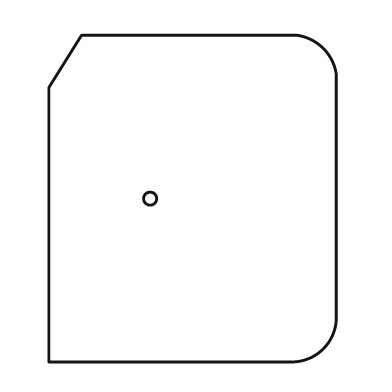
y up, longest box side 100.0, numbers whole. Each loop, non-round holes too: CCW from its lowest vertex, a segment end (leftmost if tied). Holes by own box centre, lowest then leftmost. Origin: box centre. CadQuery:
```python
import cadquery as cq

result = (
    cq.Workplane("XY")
    .moveTo(-44.0, -50.0)
    .lineTo(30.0, -50.0)
    .threePointArc((40.0, -46.0), (44.0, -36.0))
    .lineTo(44.0, 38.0)
    .threePointArc((40.0, 46.0), (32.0, 50.0))
    .lineTo(-34.0, 50.0)
    .lineTo(-44.0, 34.0)
    .close()
    .moveTo(-13.0, 0.0)
    .circle(2.0)
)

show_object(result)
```